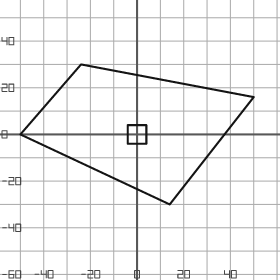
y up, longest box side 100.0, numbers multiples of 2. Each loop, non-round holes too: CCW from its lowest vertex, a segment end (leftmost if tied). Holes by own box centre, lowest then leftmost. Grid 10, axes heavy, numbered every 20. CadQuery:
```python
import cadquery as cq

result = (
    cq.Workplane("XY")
    .moveTo(14.0, -30.0)
    .lineTo(50.0, 16.0)
    .lineTo(-24.0, 30.0)
    .lineTo(-50.0, 0.0)
    .close()
    .moveTo(-4.0, -4.0)
    .lineTo(4.0, -4.0)
    .lineTo(4.0, 4.0)
    .lineTo(-4.0, 4.0)
    .close()
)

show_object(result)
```